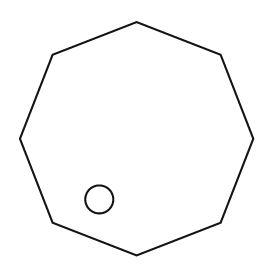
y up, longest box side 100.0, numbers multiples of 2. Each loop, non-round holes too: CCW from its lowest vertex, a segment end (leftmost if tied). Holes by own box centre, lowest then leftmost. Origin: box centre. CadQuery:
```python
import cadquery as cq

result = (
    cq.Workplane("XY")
    .moveTo(0.0, -50.0)
    .lineTo(36.0, -36.0)
    .lineTo(50.0, 0.0)
    .lineTo(36.0, 36.0)
    .lineTo(0.0, 50.0)
    .lineTo(-36.0, 36.0)
    .lineTo(-50.0, 0.0)
    .lineTo(-36.0, -36.0)
    .close()
    .moveTo(-16.0, -26.0)
    .circle(6.0)
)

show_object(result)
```